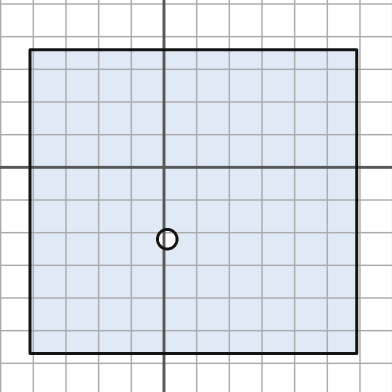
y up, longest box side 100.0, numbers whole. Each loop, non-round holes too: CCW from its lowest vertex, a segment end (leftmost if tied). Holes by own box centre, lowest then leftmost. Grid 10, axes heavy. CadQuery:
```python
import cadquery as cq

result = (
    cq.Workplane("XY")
    .moveTo(-41.0, -57.0)
    .lineTo(59.0, -57.0)
    .lineTo(59.0, 36.0)
    .lineTo(-41.0, 36.0)
    .close()
    .moveTo(1.0, -22.0)
    .circle(3.0)
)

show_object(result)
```